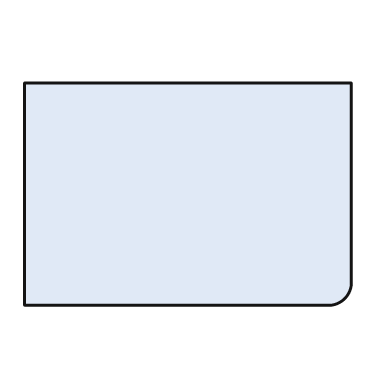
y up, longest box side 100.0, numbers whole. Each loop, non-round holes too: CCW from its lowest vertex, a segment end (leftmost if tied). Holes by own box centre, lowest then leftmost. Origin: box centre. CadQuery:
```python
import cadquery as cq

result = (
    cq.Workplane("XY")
    .moveTo(-50.0, -34.0)
    .lineTo(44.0, -34.0)
    .threePointArc((48.0, -32.0), (50.0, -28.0))
    .lineTo(50.0, 34.0)
    .lineTo(-50.0, 34.0)
    .close()
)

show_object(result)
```